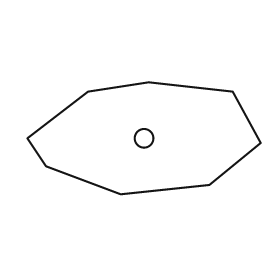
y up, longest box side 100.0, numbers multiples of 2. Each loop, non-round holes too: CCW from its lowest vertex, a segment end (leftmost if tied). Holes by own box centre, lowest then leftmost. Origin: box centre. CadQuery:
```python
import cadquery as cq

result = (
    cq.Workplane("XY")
    .moveTo(-10.0, -24.0)
    .lineTo(28.0, -20.0)
    .lineTo(50.0, -2.0)
    .lineTo(38.0, 20.0)
    .lineTo(2.0, 24.0)
    .lineTo(-24.0, 20.0)
    .lineTo(-50.0, 0.0)
    .lineTo(-42.0, -12.0)
    .close()
    .moveTo(0.0, 0.0)
    .circle(4.0)
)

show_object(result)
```